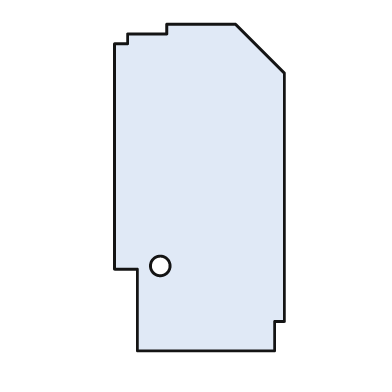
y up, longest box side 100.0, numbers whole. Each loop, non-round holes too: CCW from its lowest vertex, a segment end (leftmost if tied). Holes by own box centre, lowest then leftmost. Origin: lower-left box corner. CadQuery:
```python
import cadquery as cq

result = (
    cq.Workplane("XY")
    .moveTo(7.0, 0.0)
    .lineTo(49.0, 0.0)
    .lineTo(49.0, 9.0)
    .lineTo(52.0, 9.0)
    .lineTo(52.0, 85.0)
    .lineTo(37.0, 100.0)
    .lineTo(16.0, 100.0)
    .lineTo(16.0, 97.0)
    .lineTo(4.0, 97.0)
    .lineTo(4.0, 94.0)
    .lineTo(0.0, 94.0)
    .lineTo(0.0, 25.0)
    .lineTo(7.0, 25.0)
    .close()
    .moveTo(14.0, 26.0)
    .circle(3.0)
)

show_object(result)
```